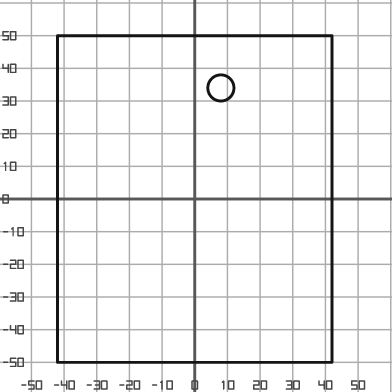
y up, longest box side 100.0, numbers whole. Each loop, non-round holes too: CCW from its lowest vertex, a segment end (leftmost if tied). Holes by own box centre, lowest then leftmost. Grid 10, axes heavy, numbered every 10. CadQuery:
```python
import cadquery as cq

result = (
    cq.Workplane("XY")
    .moveTo(-42.0, -50.0)
    .lineTo(42.0, -50.0)
    .lineTo(42.0, 50.0)
    .lineTo(-42.0, 50.0)
    .close()
    .moveTo(8.0, 34.0)
    .circle(4.0)
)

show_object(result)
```